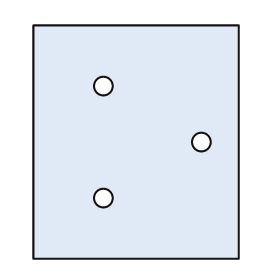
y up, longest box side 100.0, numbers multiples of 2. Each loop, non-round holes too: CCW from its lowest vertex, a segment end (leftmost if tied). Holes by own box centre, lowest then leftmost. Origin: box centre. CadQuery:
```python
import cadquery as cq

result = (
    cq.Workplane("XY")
    .moveTo(-44.0, -50.0)
    .lineTo(44.0, -50.0)
    .lineTo(44.0, 50.0)
    .lineTo(-44.0, 50.0)
    .close()
    .moveTo(-14.0, -24.0)
    .circle(4.0)
    .moveTo(28.0, 0.0)
    .circle(4.0)
    .moveTo(-14.0, 24.0)
    .circle(4.0)
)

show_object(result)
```